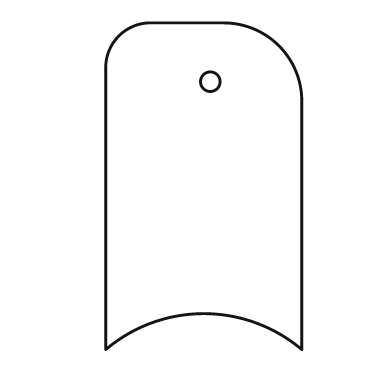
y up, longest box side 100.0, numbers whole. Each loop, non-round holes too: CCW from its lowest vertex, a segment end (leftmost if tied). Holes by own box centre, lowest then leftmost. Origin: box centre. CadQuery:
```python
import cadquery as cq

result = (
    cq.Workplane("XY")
    .moveTo(-30.0, -50.0)
    .threePointArc((0.0, -39.0), (30.0, -50.0))
    .lineTo(30.0, 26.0)
    .threePointArc((23.0, 43.0), (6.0, 50.0))
    .lineTo(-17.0, 50.0)
    .threePointArc((-26.0, 46.0), (-30.0, 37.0))
    .close()
    .moveTo(2.0, 32.0)
    .circle(3.0)
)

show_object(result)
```